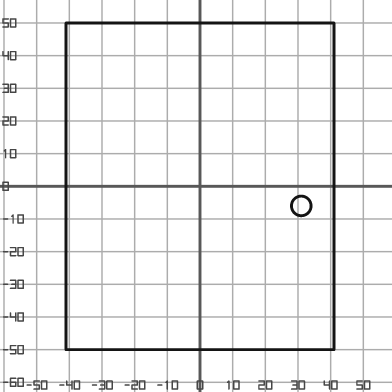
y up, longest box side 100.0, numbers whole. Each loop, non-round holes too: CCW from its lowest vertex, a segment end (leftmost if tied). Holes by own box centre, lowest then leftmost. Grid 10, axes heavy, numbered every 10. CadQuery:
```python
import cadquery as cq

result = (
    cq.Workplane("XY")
    .moveTo(-41.0, -50.0)
    .lineTo(41.0, -50.0)
    .lineTo(41.0, 50.0)
    .lineTo(-41.0, 50.0)
    .close()
    .moveTo(31.0, -6.0)
    .circle(3.0)
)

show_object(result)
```